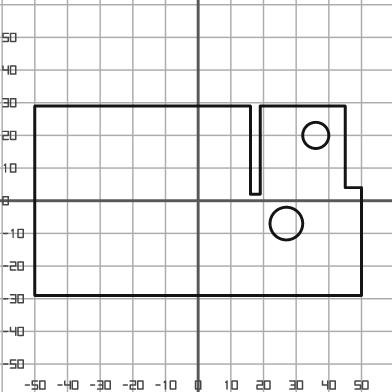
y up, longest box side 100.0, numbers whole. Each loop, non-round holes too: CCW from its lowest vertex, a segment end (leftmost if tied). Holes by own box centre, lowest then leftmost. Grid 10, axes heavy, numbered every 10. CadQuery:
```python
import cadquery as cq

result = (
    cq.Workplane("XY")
    .moveTo(-50.0, -29.0)
    .lineTo(50.0, -29.0)
    .lineTo(50.0, 4.0)
    .lineTo(45.0, 4.0)
    .lineTo(45.0, 29.0)
    .lineTo(19.0, 29.0)
    .lineTo(19.0, 2.0)
    .lineTo(16.0, 2.0)
    .lineTo(16.0, 29.0)
    .lineTo(-50.0, 29.0)
    .close()
    .moveTo(27.0, -7.0)
    .circle(5.0)
    .moveTo(36.0, 20.0)
    .circle(4.0)
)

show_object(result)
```